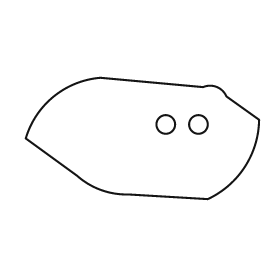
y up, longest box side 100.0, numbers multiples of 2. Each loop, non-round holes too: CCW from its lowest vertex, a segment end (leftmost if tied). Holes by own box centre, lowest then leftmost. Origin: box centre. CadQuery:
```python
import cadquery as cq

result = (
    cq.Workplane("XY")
    .moveTo(28.0, -26.0)
    .threePointArc((44.0, -12.0), (50.0, 8.0))
    .lineTo(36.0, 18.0)
    .threePointArc((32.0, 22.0), (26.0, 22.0))
    .lineTo(-18.0, 26.0)
    .threePointArc((-38.0, 18.0), (-50.0, 0.0))
    .lineTo(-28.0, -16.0)
    .threePointArc((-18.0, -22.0), (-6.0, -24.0))
    .close()
    .moveTo(10.0, 6.0)
    .circle(4.0)
    .moveTo(24.0, 6.0)
    .circle(4.0)
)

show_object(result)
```